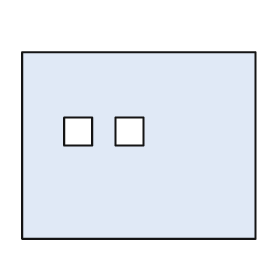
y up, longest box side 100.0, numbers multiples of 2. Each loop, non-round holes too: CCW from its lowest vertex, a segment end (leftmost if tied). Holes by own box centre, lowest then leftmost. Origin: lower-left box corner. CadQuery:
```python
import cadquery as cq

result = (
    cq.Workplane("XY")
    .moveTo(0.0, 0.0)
    .lineTo(100.0, 0.0)
    .lineTo(100.0, 80.0)
    .lineTo(0.0, 80.0)
    .close()
    .moveTo(18.0, 40.0)
    .lineTo(30.0, 40.0)
    .lineTo(30.0, 52.0)
    .lineTo(18.0, 52.0)
    .close()
    .moveTo(40.0, 40.0)
    .lineTo(52.0, 40.0)
    .lineTo(52.0, 52.0)
    .lineTo(40.0, 52.0)
    .close()
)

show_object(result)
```